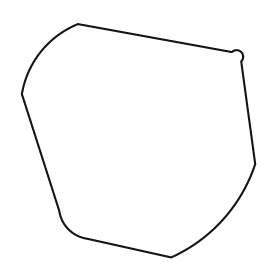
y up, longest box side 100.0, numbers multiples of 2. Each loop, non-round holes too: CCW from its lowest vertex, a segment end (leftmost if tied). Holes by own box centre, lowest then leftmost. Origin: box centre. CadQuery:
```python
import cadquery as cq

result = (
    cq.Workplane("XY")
    .moveTo(14.0, -50.0)
    .threePointArc((36.0, -34.0), (50.0, -10.0))
    .lineTo(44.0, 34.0)
    .threePointArc((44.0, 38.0), (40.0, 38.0))
    .lineTo(-26.0, 50.0)
    .threePointArc((-42.0, 38.0), (-50.0, 20.0))
    .lineTo(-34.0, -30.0)
    .threePointArc((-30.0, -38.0), (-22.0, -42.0))
    .close()
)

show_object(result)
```